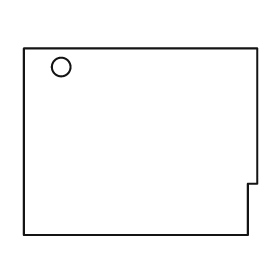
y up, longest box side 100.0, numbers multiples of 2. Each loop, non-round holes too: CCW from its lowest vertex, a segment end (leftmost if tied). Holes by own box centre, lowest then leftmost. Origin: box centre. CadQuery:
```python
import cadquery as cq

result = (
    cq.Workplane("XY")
    .moveTo(-50.0, -40.0)
    .lineTo(46.0, -40.0)
    .lineTo(46.0, -18.0)
    .lineTo(50.0, -18.0)
    .lineTo(50.0, 40.0)
    .lineTo(-50.0, 40.0)
    .close()
    .moveTo(-34.0, 32.0)
    .circle(4.0)
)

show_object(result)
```